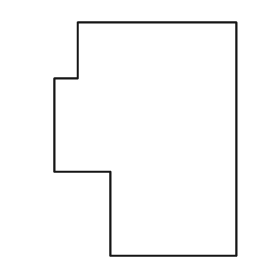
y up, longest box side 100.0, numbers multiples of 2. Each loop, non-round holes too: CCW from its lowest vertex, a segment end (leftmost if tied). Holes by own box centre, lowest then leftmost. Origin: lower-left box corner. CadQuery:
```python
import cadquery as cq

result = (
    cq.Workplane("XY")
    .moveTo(24.0, 0.0)
    .lineTo(78.0, 0.0)
    .lineTo(78.0, 100.0)
    .lineTo(10.0, 100.0)
    .lineTo(10.0, 76.0)
    .lineTo(0.0, 76.0)
    .lineTo(0.0, 36.0)
    .lineTo(24.0, 36.0)
    .close()
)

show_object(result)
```